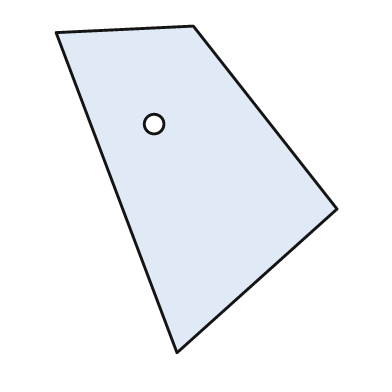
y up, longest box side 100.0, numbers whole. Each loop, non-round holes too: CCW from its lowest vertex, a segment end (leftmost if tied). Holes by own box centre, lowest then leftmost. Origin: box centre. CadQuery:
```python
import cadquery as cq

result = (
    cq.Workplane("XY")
    .moveTo(-6.0, -50.0)
    .lineTo(43.0, -6.0)
    .lineTo(-1.0, 50.0)
    .lineTo(-43.0, 48.0)
    .close()
    .moveTo(-13.0, 20.0)
    .circle(3.0)
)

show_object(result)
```